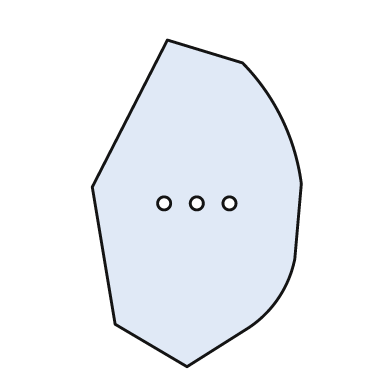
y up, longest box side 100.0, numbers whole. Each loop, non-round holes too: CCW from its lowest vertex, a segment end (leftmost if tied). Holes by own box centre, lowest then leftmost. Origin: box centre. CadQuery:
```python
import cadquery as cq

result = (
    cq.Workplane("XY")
    .moveTo(-3.0, -50.0)
    .lineTo(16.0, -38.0)
    .threePointArc((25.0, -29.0), (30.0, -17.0))
    .lineTo(32.0, 6.0)
    .threePointArc((26.0, 26.0), (14.0, 43.0))
    .lineTo(-9.0, 50.0)
    .lineTo(-32.0, 5.0)
    .lineTo(-25.0, -37.0)
    .close()
    .moveTo(-10.0, 0.0)
    .circle(2.0)
    .moveTo(0.0, 0.0)
    .circle(2.0)
    .moveTo(10.0, 0.0)
    .circle(2.0)
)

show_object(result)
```